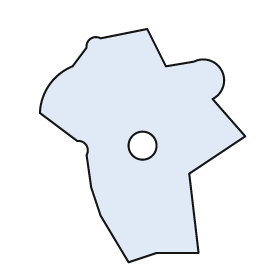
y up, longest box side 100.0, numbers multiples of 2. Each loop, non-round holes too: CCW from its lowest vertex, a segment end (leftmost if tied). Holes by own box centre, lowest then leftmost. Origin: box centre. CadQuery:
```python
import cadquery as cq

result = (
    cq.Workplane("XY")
    .moveTo(-6.0, -50.0)
    .lineTo(6.0, -46.0)
    .lineTo(24.0, -46.0)
    .lineTo(20.0, -12.0)
    .lineTo(44.0, 4.0)
    .lineTo(30.0, 20.0)
    .threePointArc((34.0, 32.0), (22.0, 36.0))
    .lineTo(10.0, 34.0)
    .lineTo(2.0, 50.0)
    .lineTo(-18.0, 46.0)
    .threePointArc((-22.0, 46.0), (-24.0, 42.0))
    .lineTo(-30.0, 34.0)
    .threePointArc((-40.0, 26.0), (-44.0, 14.0))
    .lineTo(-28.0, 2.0)
    .threePointArc((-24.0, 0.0), (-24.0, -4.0))
    .lineTo(-22.0, -18.0)
    .lineTo(-18.0, -30.0)
    .close()
    .moveTo(0.0, 0.0)
    .circle(6.0)
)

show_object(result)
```